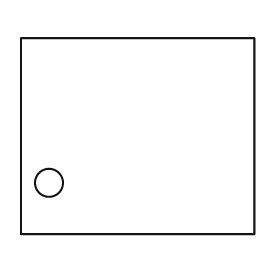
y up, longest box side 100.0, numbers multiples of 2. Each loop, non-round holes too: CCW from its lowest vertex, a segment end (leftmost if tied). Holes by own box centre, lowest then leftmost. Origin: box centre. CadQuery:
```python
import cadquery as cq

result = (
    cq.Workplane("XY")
    .moveTo(-50.0, -42.0)
    .lineTo(50.0, -42.0)
    .lineTo(50.0, 42.0)
    .lineTo(-50.0, 42.0)
    .close()
    .moveTo(-38.0, -20.0)
    .circle(6.0)
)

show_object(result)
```